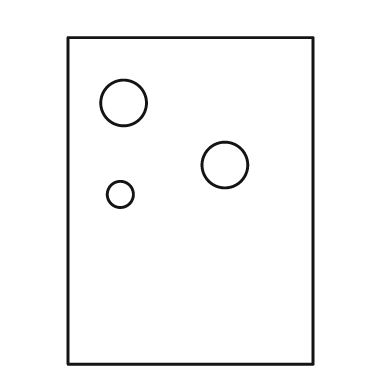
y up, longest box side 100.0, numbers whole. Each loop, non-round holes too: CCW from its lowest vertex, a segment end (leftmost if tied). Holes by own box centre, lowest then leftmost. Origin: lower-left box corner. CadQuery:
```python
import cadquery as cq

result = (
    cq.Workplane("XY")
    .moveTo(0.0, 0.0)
    .lineTo(75.0, 0.0)
    .lineTo(75.0, 100.0)
    .lineTo(0.0, 100.0)
    .close()
    .moveTo(16.0, 52.0)
    .circle(4.0)
    .moveTo(48.0, 61.0)
    .circle(7.0)
    .moveTo(17.0, 80.0)
    .circle(7.0)
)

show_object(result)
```